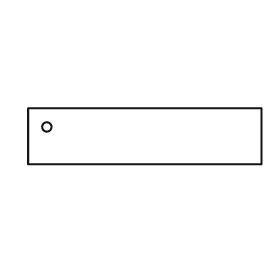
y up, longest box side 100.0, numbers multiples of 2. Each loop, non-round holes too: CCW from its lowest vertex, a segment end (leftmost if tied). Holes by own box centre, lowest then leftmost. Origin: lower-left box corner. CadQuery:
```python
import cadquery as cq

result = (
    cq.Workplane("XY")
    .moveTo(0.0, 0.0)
    .lineTo(100.0, 0.0)
    .lineTo(100.0, 24.0)
    .lineTo(0.0, 24.0)
    .close()
    .moveTo(8.0, 16.0)
    .circle(2.0)
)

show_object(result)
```